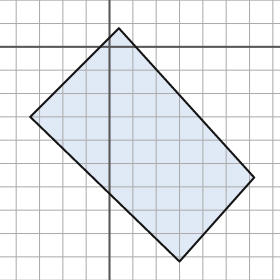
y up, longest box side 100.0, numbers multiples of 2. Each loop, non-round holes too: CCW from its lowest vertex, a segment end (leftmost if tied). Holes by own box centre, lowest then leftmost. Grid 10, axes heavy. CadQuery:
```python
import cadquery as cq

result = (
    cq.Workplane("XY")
    .moveTo(30.0, -92.0)
    .lineTo(62.0, -56.0)
    .lineTo(4.0, 8.0)
    .lineTo(-34.0, -30.0)
    .close()
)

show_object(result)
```